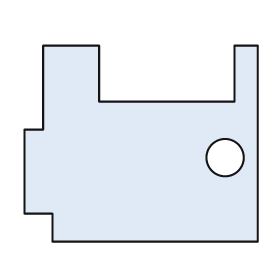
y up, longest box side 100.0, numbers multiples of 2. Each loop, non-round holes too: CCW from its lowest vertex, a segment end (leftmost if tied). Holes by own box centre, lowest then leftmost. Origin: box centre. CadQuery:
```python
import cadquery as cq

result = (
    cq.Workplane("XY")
    .moveTo(-38.0, -42.0)
    .lineTo(50.0, -42.0)
    .lineTo(50.0, 42.0)
    .lineTo(40.0, 42.0)
    .lineTo(40.0, 18.0)
    .lineTo(-18.0, 18.0)
    .lineTo(-18.0, 42.0)
    .lineTo(-42.0, 42.0)
    .lineTo(-42.0, 6.0)
    .lineTo(-50.0, 6.0)
    .lineTo(-50.0, -30.0)
    .lineTo(-38.0, -30.0)
    .close()
    .moveTo(36.0, -6.0)
    .circle(8.0)
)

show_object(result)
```